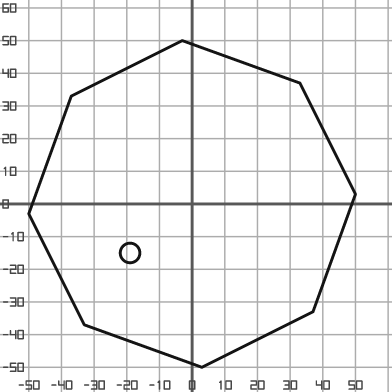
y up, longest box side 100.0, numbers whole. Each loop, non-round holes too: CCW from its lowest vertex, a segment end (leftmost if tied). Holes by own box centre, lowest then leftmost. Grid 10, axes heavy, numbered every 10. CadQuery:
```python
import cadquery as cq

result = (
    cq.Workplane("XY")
    .moveTo(3.0, -50.0)
    .lineTo(37.0, -33.0)
    .lineTo(50.0, 3.0)
    .lineTo(33.0, 37.0)
    .lineTo(-3.0, 50.0)
    .lineTo(-37.0, 33.0)
    .lineTo(-50.0, -3.0)
    .lineTo(-33.0, -37.0)
    .close()
    .moveTo(-19.0, -15.0)
    .circle(3.0)
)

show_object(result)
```